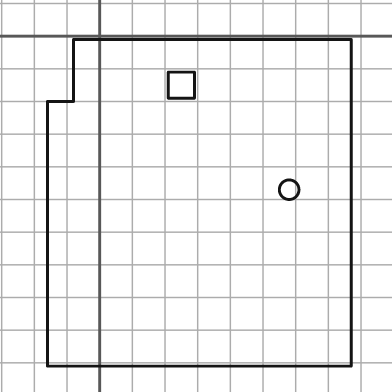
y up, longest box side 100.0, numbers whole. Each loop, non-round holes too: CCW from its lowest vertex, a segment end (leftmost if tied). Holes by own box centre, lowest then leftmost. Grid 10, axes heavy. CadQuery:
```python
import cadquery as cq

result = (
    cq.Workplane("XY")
    .moveTo(-16.0, -101.0)
    .lineTo(77.0, -101.0)
    .lineTo(77.0, -1.0)
    .lineTo(-8.0, -1.0)
    .lineTo(-8.0, -20.0)
    .lineTo(-16.0, -20.0)
    .close()
    .moveTo(58.0, -47.0)
    .circle(3.0)
    .moveTo(21.0, -19.0)
    .lineTo(29.0, -19.0)
    .lineTo(29.0, -11.0)
    .lineTo(21.0, -11.0)
    .close()
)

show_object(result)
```